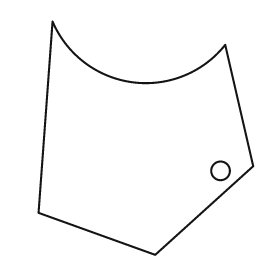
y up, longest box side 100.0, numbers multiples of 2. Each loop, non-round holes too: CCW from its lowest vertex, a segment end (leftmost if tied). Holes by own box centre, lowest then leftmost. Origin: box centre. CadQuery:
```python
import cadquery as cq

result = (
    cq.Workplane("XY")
    .moveTo(4.0, -50.0)
    .lineTo(46.0, -12.0)
    .lineTo(34.0, 40.0)
    .threePointArc((-6.0, 24.0), (-40.0, 50.0))
    .lineTo(-46.0, -32.0)
    .close()
    .moveTo(32.0, -14.0)
    .circle(4.0)
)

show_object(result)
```